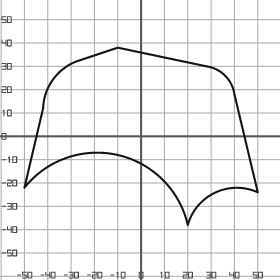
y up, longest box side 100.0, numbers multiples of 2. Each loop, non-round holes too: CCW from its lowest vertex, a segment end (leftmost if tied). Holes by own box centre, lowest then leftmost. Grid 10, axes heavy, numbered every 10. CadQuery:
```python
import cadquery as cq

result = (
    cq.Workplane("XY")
    .moveTo(20.0, -38.0)
    .threePointArc((32.0, -24.0), (50.0, -24.0))
    .lineTo(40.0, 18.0)
    .threePointArc((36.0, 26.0), (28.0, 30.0))
    .lineTo(-10.0, 38.0)
    .lineTo(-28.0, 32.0)
    .threePointArc((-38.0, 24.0), (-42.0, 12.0))
    .lineTo(-50.0, -22.0)
    .threePointArc((-10.0, -8.0), (20.0, -38.0))
    .close()
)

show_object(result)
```